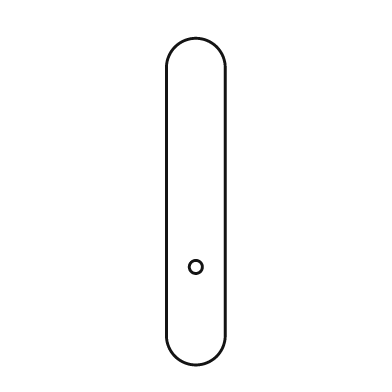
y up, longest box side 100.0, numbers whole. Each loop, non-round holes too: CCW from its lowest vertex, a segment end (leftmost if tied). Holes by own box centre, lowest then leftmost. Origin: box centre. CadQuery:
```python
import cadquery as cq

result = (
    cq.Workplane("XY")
    .moveTo(-9.0, -41.0)
    .threePointArc((0.0, -50.0), (9.0, -41.0))
    .lineTo(9.0, 41.0)
    .threePointArc((0.0, 50.0), (-9.0, 41.0))
    .close()
    .moveTo(0.0, -20.0)
    .circle(2.0)
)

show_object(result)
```